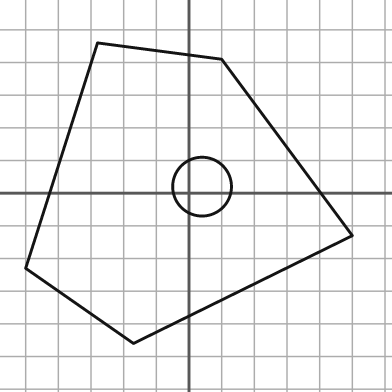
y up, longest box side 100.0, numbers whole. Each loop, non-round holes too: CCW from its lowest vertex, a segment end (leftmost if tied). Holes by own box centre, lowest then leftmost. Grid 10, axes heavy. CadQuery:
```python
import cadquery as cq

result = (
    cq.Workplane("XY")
    .moveTo(-17.0, -46.0)
    .lineTo(50.0, -13.0)
    .lineTo(10.0, 41.0)
    .lineTo(-28.0, 46.0)
    .lineTo(-50.0, -23.0)
    .close()
    .moveTo(4.0, 2.0)
    .circle(9.0)
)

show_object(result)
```